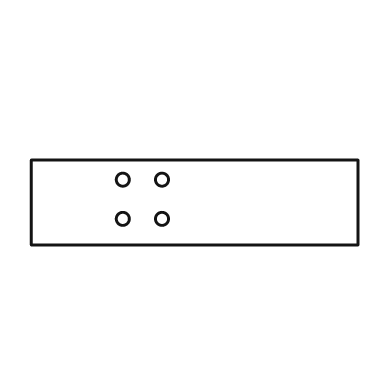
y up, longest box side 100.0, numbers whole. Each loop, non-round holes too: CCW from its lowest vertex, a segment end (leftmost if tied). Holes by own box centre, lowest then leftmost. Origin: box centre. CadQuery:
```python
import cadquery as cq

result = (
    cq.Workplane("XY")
    .moveTo(-50.0, -13.0)
    .lineTo(50.0, -13.0)
    .lineTo(50.0, 13.0)
    .lineTo(-50.0, 13.0)
    .close()
    .moveTo(-22.0, -5.0)
    .circle(2.0)
    .moveTo(-10.0, -5.0)
    .circle(2.0)
    .moveTo(-22.0, 7.0)
    .circle(2.0)
    .moveTo(-10.0, 7.0)
    .circle(2.0)
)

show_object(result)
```